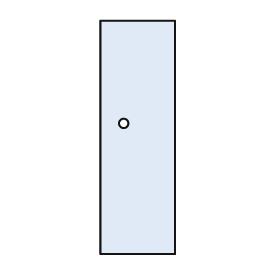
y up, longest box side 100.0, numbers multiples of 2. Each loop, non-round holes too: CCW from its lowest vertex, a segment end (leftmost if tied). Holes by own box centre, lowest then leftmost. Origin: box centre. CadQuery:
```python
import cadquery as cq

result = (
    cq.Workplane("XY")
    .moveTo(-16.0, -50.0)
    .lineTo(16.0, -50.0)
    .lineTo(16.0, 50.0)
    .lineTo(-16.0, 50.0)
    .close()
    .moveTo(-6.0, 6.0)
    .circle(2.0)
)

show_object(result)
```